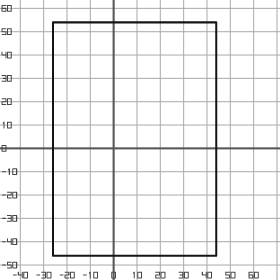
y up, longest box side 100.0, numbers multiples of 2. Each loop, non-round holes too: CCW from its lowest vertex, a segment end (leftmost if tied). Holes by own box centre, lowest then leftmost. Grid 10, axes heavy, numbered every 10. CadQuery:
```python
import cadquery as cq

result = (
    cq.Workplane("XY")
    .moveTo(-26.0, -46.0)
    .lineTo(44.0, -46.0)
    .lineTo(44.0, 54.0)
    .lineTo(-26.0, 54.0)
    .close()
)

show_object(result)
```